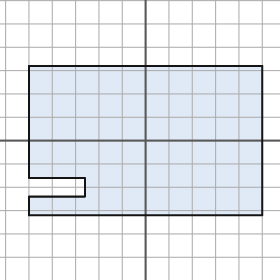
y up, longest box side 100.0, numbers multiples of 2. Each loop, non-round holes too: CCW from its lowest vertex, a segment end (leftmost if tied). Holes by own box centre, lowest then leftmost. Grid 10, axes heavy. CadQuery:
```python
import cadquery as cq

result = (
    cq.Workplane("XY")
    .moveTo(-50.0, -32.0)
    .lineTo(50.0, -32.0)
    .lineTo(50.0, 32.0)
    .lineTo(-50.0, 32.0)
    .lineTo(-50.0, -16.0)
    .lineTo(-26.0, -16.0)
    .lineTo(-26.0, -24.0)
    .lineTo(-50.0, -24.0)
    .close()
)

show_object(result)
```